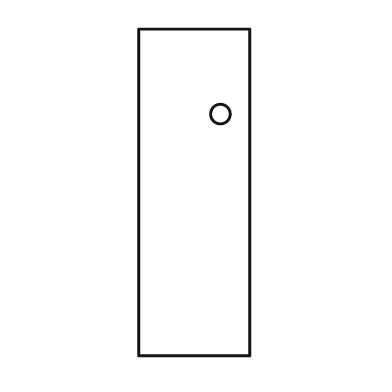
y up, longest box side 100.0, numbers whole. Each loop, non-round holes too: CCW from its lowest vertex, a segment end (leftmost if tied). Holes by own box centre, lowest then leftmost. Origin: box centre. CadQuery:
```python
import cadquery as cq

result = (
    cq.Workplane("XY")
    .moveTo(-17.0, -50.0)
    .lineTo(17.0, -50.0)
    .lineTo(17.0, 50.0)
    .lineTo(-17.0, 50.0)
    .close()
    .moveTo(8.0, 24.0)
    .circle(3.0)
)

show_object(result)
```